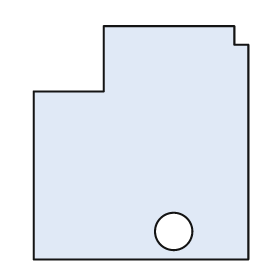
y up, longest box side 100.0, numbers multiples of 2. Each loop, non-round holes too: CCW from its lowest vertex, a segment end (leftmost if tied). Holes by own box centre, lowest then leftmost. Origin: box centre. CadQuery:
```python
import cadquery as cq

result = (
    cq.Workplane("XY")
    .moveTo(-46.0, -50.0)
    .lineTo(46.0, -50.0)
    .lineTo(46.0, 42.0)
    .lineTo(40.0, 42.0)
    .lineTo(40.0, 50.0)
    .lineTo(-16.0, 50.0)
    .lineTo(-16.0, 22.0)
    .lineTo(-46.0, 22.0)
    .close()
    .moveTo(14.0, -38.0)
    .circle(8.0)
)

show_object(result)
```